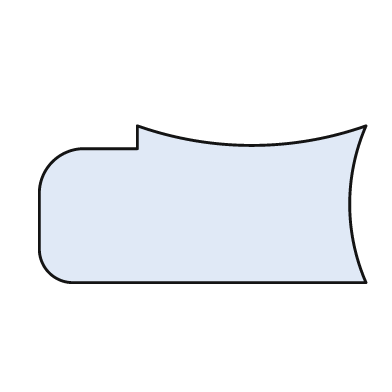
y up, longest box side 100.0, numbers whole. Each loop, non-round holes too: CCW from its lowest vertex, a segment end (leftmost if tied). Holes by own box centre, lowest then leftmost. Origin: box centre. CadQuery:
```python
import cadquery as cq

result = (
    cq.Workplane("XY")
    .moveTo(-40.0, -24.0)
    .lineTo(50.0, -24.0)
    .threePointArc((45.0, 0.0), (50.0, 24.0))
    .threePointArc((15.0, 18.0), (-20.0, 24.0))
    .lineTo(-20.0, 17.0)
    .lineTo(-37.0, 17.0)
    .threePointArc((-46.0, 13.0), (-50.0, 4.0))
    .lineTo(-50.0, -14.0)
    .threePointArc((-47.0, -21.0), (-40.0, -24.0))
    .close()
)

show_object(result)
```